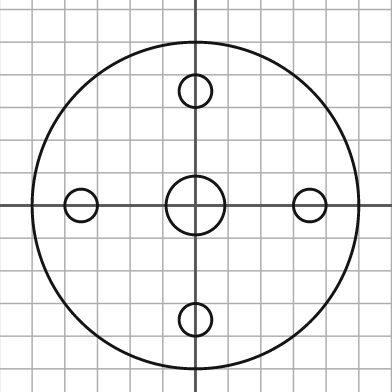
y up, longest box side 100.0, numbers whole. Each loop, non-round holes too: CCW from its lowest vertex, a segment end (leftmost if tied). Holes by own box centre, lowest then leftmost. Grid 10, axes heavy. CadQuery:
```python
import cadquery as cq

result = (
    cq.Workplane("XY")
    .moveTo(0.0, 0.0)
    .circle(50.0)
    .moveTo(0.0, -35.0)
    .circle(5.0)
    .moveTo(-35.0, 0.0)
    .circle(5.0)
    .moveTo(0.0, 0.0)
    .circle(9.0)
    .moveTo(35.0, 0.0)
    .circle(5.0)
    .moveTo(0.0, 35.0)
    .circle(5.0)
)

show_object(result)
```